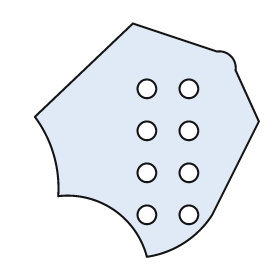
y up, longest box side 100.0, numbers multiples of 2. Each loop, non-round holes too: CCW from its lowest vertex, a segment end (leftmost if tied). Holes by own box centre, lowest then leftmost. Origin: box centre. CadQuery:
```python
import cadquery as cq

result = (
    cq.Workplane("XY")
    .moveTo(0.0, -50.0)
    .threePointArc((16.0, -44.0), (28.0, -32.0))
    .lineTo(48.0, 8.0)
    .lineTo(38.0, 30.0)
    .threePointArc((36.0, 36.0), (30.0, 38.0))
    .lineTo(-6.0, 50.0)
    .lineTo(-48.0, 10.0)
    .threePointArc((-40.0, -6.0), (-38.0, -24.0))
    .threePointArc((-14.0, -30.0), (0.0, -50.0))
    .close()
    .moveTo(0.0, -32.0)
    .circle(4.0)
    .moveTo(18.0, -32.0)
    .circle(4.0)
    .moveTo(0.0, -14.0)
    .circle(4.0)
    .moveTo(18.0, -14.0)
    .circle(4.0)
    .moveTo(0.0, 4.0)
    .circle(4.0)
    .moveTo(18.0, 4.0)
    .circle(4.0)
    .moveTo(0.0, 22.0)
    .circle(4.0)
    .moveTo(18.0, 22.0)
    .circle(4.0)
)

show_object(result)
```